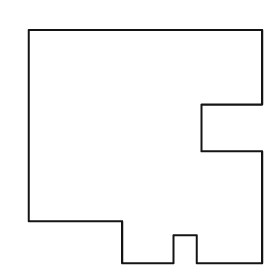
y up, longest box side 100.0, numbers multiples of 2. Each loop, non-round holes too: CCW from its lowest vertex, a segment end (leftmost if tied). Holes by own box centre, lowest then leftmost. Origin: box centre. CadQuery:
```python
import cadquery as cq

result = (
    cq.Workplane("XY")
    .moveTo(-10.0, -50.0)
    .lineTo(12.0, -50.0)
    .lineTo(12.0, -38.0)
    .lineTo(22.0, -38.0)
    .lineTo(22.0, -50.0)
    .lineTo(50.0, -50.0)
    .lineTo(50.0, -2.0)
    .lineTo(24.0, -2.0)
    .lineTo(24.0, 18.0)
    .lineTo(50.0, 18.0)
    .lineTo(50.0, 50.0)
    .lineTo(-50.0, 50.0)
    .lineTo(-50.0, -32.0)
    .lineTo(-10.0, -32.0)
    .close()
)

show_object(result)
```